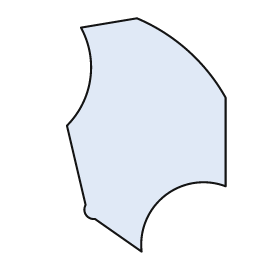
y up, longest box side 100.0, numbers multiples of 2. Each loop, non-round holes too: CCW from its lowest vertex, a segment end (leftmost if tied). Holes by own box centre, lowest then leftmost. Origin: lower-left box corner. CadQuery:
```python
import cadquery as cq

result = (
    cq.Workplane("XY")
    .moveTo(32.0, 0.0)
    .threePointArc((42.0, 24.0), (68.0, 28.0))
    .lineTo(68.0, 66.0)
    .threePointArc((52.0, 86.0), (30.0, 100.0))
    .lineTo(6.0, 96.0)
    .threePointArc((10.0, 74.0), (0.0, 54.0))
    .lineTo(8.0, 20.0)
    .threePointArc((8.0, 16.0), (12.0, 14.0))
    .close()
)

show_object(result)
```